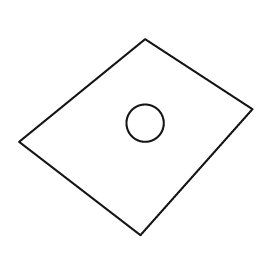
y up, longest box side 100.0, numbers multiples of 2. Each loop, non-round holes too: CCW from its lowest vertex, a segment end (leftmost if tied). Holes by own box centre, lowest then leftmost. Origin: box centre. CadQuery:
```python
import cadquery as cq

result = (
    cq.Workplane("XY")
    .moveTo(2.0, -42.0)
    .lineTo(50.0, 12.0)
    .lineTo(4.0, 42.0)
    .lineTo(-50.0, -2.0)
    .close()
    .moveTo(4.0, 6.0)
    .circle(8.0)
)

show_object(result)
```